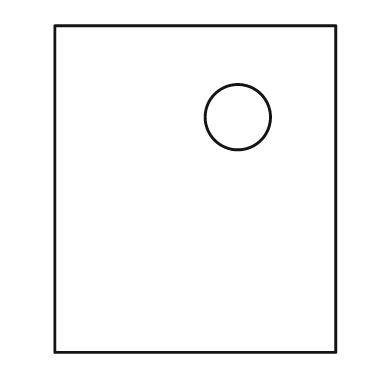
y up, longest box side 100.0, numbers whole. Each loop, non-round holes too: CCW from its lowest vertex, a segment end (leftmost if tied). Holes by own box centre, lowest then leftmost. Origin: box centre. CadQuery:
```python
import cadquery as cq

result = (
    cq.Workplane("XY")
    .moveTo(-43.0, -50.0)
    .lineTo(43.0, -50.0)
    .lineTo(43.0, 50.0)
    .lineTo(-43.0, 50.0)
    .close()
    .moveTo(13.0, 22.0)
    .circle(10.0)
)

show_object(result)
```